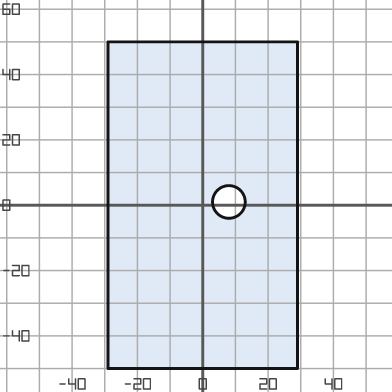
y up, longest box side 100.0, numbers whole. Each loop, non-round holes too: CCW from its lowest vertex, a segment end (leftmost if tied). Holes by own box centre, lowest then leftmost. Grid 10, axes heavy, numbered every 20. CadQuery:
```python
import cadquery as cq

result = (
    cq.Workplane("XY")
    .moveTo(-29.0, -50.0)
    .lineTo(29.0, -50.0)
    .lineTo(29.0, 50.0)
    .lineTo(-29.0, 50.0)
    .close()
    .moveTo(8.0, 1.0)
    .circle(5.0)
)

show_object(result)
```